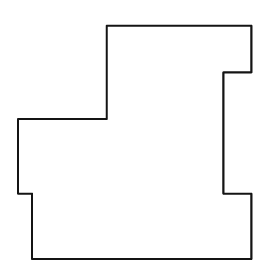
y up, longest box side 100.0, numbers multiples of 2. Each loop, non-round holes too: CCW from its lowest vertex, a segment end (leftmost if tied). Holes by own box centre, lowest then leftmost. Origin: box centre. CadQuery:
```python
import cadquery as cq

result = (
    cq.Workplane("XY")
    .moveTo(-44.0, -50.0)
    .lineTo(50.0, -50.0)
    .lineTo(50.0, -22.0)
    .lineTo(38.0, -22.0)
    .lineTo(38.0, 30.0)
    .lineTo(50.0, 30.0)
    .lineTo(50.0, 50.0)
    .lineTo(-12.0, 50.0)
    .lineTo(-12.0, 10.0)
    .lineTo(-50.0, 10.0)
    .lineTo(-50.0, -22.0)
    .lineTo(-44.0, -22.0)
    .close()
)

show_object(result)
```